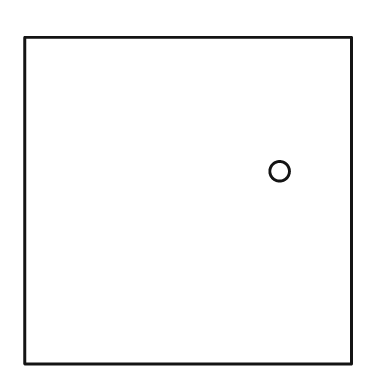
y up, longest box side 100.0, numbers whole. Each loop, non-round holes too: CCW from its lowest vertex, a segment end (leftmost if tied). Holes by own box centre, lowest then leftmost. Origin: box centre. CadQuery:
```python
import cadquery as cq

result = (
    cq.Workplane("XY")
    .moveTo(-50.0, -50.0)
    .lineTo(50.0, -50.0)
    .lineTo(50.0, 50.0)
    .lineTo(-50.0, 50.0)
    .close()
    .moveTo(28.0, 9.0)
    .circle(3.0)
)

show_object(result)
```